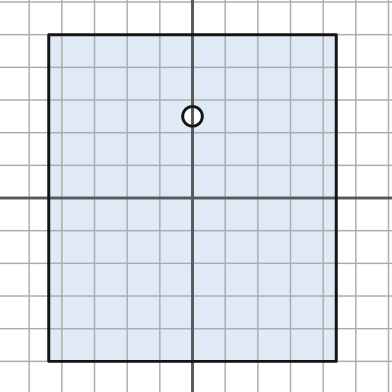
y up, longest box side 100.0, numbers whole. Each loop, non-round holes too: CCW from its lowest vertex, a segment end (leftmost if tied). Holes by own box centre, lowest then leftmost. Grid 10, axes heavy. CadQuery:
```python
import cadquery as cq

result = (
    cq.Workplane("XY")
    .moveTo(-44.0, -50.0)
    .lineTo(44.0, -50.0)
    .lineTo(44.0, 50.0)
    .lineTo(-44.0, 50.0)
    .close()
    .moveTo(0.0, 25.0)
    .circle(3.0)
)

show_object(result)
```